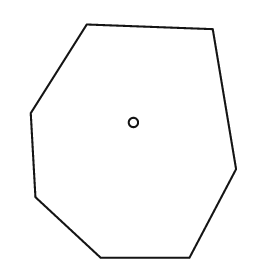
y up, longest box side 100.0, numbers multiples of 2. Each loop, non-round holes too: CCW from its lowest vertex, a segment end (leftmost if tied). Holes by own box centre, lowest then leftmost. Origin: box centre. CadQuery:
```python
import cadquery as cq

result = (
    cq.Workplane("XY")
    .moveTo(-14.0, -50.0)
    .lineTo(24.0, -50.0)
    .lineTo(44.0, -12.0)
    .lineTo(34.0, 48.0)
    .lineTo(-20.0, 50.0)
    .lineTo(-44.0, 12.0)
    .lineTo(-42.0, -24.0)
    .close()
    .moveTo(0.0, 8.0)
    .circle(2.0)
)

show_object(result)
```